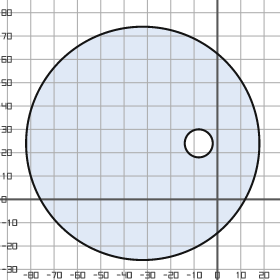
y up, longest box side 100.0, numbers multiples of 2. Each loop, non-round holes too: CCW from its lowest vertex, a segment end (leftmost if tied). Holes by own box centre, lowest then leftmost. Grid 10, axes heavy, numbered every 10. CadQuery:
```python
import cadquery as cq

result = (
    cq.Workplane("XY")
    .moveTo(-32.0, 24.0)
    .circle(50.0)
    .moveTo(-8.0, 24.0)
    .circle(6.0)
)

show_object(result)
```